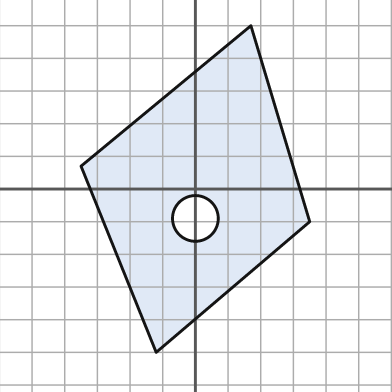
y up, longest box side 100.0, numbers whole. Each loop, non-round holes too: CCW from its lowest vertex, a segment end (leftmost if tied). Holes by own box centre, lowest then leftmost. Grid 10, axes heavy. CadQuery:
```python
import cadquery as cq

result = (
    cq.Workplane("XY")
    .moveTo(-12.0, -50.0)
    .lineTo(35.0, -10.0)
    .lineTo(17.0, 50.0)
    .lineTo(-35.0, 7.0)
    .close()
    .moveTo(0.0, -9.0)
    .circle(7.0)
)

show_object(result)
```